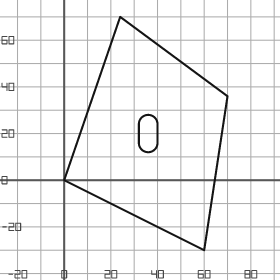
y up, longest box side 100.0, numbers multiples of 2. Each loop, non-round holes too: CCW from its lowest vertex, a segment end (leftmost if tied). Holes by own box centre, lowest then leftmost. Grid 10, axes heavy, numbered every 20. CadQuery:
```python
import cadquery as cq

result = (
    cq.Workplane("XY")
    .moveTo(60.0, -30.0)
    .lineTo(70.0, 36.0)
    .lineTo(24.0, 70.0)
    .lineTo(0.0, 0.0)
    .close()
    .moveTo(32.0, 16.0)
    .threePointArc((36.0, 12.0), (40.0, 16.0))
    .lineTo(40.0, 24.0)
    .threePointArc((36.0, 28.0), (32.0, 24.0))
    .close()
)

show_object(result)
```